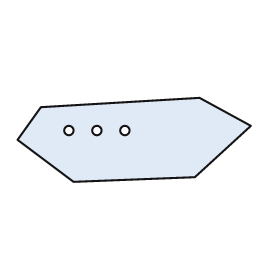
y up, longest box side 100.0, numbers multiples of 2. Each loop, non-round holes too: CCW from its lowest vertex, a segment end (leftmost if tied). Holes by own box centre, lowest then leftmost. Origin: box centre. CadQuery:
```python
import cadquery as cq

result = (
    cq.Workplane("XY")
    .moveTo(-26.0, -18.0)
    .lineTo(26.0, -16.0)
    .lineTo(50.0, 6.0)
    .lineTo(28.0, 18.0)
    .lineTo(-40.0, 14.0)
    .lineTo(-50.0, 0.0)
    .close()
    .moveTo(-28.0, 4.0)
    .circle(2.0)
    .moveTo(-16.0, 4.0)
    .circle(2.0)
    .moveTo(-4.0, 4.0)
    .circle(2.0)
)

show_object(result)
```